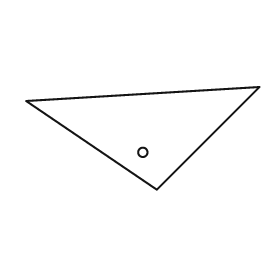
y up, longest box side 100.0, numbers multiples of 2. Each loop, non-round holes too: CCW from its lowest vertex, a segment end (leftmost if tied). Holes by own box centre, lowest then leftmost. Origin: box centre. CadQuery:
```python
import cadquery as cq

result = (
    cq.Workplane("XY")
    .moveTo(6.0, -22.0)
    .lineTo(50.0, 22.0)
    .lineTo(-50.0, 16.0)
    .close()
    .moveTo(0.0, -6.0)
    .circle(2.0)
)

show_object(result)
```